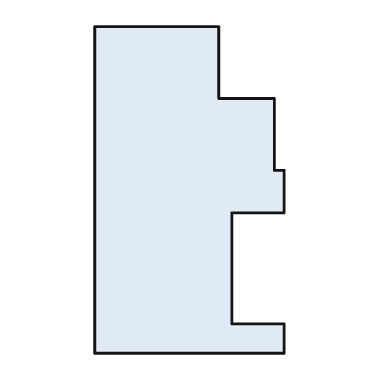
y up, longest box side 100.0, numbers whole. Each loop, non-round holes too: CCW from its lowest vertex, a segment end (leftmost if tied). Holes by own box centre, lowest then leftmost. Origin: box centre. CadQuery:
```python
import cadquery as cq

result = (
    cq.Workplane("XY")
    .moveTo(-29.0, -50.0)
    .lineTo(29.0, -50.0)
    .lineTo(29.0, -41.0)
    .lineTo(13.0, -41.0)
    .lineTo(13.0, -7.0)
    .lineTo(29.0, -7.0)
    .lineTo(29.0, 6.0)
    .lineTo(26.0, 6.0)
    .lineTo(26.0, 28.0)
    .lineTo(9.0, 28.0)
    .lineTo(9.0, 50.0)
    .lineTo(-29.0, 50.0)
    .close()
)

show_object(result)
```